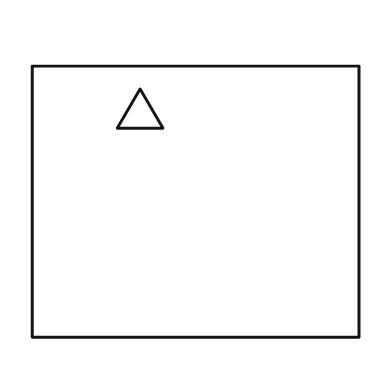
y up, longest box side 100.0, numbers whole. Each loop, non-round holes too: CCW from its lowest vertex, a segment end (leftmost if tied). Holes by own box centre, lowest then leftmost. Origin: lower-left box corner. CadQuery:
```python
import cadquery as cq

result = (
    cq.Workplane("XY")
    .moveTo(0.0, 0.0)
    .lineTo(100.0, 0.0)
    .lineTo(100.0, 83.0)
    .lineTo(0.0, 83.0)
    .close()
    .moveTo(26.0, 64.0)
    .lineTo(40.0, 64.0)
    .lineTo(33.0, 76.0)
    .close()
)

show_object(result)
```